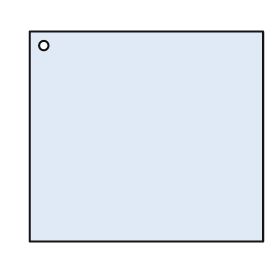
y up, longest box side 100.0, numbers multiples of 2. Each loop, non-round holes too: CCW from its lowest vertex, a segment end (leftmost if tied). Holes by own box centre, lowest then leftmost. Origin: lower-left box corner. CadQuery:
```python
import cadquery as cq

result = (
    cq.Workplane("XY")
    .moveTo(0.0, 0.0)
    .lineTo(100.0, 0.0)
    .lineTo(100.0, 90.0)
    .lineTo(0.0, 90.0)
    .close()
    .moveTo(6.0, 84.0)
    .circle(2.0)
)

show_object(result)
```